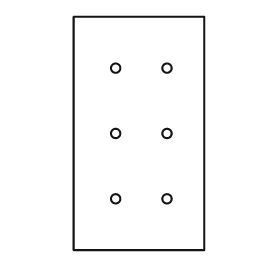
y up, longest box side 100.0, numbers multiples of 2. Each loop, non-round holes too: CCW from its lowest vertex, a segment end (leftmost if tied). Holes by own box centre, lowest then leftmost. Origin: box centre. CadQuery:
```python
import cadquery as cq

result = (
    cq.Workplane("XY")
    .moveTo(-28.0, -50.0)
    .lineTo(28.0, -50.0)
    .lineTo(28.0, 50.0)
    .lineTo(-28.0, 50.0)
    .close()
    .moveTo(-10.0, -28.0)
    .circle(2.0)
    .moveTo(12.0, -28.0)
    .circle(2.0)
    .moveTo(-10.0, 0.0)
    .circle(2.0)
    .moveTo(12.0, 0.0)
    .circle(2.0)
    .moveTo(-10.0, 28.0)
    .circle(2.0)
    .moveTo(12.0, 28.0)
    .circle(2.0)
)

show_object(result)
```